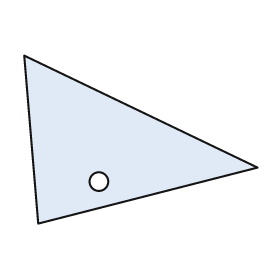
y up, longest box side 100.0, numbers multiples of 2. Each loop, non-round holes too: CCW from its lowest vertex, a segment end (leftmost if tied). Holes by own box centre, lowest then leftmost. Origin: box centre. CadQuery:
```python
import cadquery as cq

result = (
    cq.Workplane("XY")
    .moveTo(-44.0, -36.0)
    .lineTo(50.0, -12.0)
    .lineTo(-50.0, 36.0)
    .close()
    .moveTo(-18.0, -18.0)
    .circle(4.0)
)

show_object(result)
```